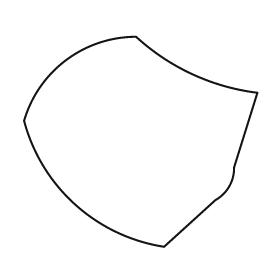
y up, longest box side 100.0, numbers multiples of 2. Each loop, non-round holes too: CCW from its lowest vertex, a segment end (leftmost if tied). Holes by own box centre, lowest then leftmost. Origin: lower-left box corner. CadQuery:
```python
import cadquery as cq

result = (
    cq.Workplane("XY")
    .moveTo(60.0, 0.0)
    .lineTo(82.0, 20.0)
    .threePointArc((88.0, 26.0), (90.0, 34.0))
    .lineTo(100.0, 66.0)
    .threePointArc((72.0, 74.0), (48.0, 90.0))
    .threePointArc((18.0, 80.0), (0.0, 54.0))
    .threePointArc((22.0, 18.0), (60.0, 0.0))
    .close()
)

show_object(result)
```